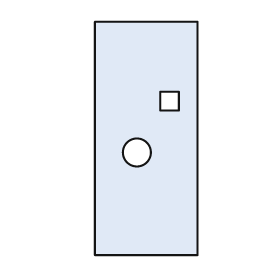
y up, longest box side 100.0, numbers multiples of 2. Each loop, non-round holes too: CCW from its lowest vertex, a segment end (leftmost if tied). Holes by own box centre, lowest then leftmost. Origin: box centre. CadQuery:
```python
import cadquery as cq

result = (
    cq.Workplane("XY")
    .moveTo(-22.0, -50.0)
    .lineTo(22.0, -50.0)
    .lineTo(22.0, 50.0)
    .lineTo(-22.0, 50.0)
    .close()
    .moveTo(-4.0, -6.0)
    .circle(6.0)
    .moveTo(6.0, 12.0)
    .lineTo(14.0, 12.0)
    .lineTo(14.0, 20.0)
    .lineTo(6.0, 20.0)
    .close()
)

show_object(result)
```